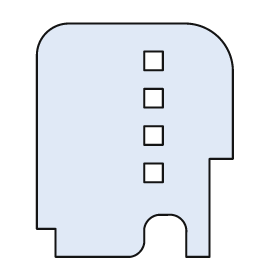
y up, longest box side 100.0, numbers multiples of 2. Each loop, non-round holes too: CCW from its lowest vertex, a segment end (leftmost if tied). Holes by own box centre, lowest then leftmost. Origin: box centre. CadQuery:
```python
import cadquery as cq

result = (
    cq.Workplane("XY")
    .moveTo(-34.0, -50.0)
    .lineTo(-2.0, -50.0)
    .threePointArc((2.0, -48.0), (4.0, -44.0))
    .lineTo(4.0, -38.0)
    .threePointArc((6.0, -34.0), (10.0, -32.0))
    .lineTo(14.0, -32.0)
    .threePointArc((20.0, -34.0), (22.0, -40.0))
    .lineTo(22.0, -50.0)
    .lineTo(32.0, -50.0)
    .lineTo(32.0, -8.0)
    .lineTo(42.0, -8.0)
    .lineTo(42.0, 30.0)
    .threePointArc((36.0, 44.0), (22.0, 50.0))
    .lineTo(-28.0, 50.0)
    .threePointArc((-38.0, 46.0), (-42.0, 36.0))
    .lineTo(-42.0, -38.0)
    .lineTo(-34.0, -38.0)
    .close()
    .moveTo(4.0, -18.0)
    .lineTo(12.0, -18.0)
    .lineTo(12.0, -10.0)
    .lineTo(4.0, -10.0)
    .close()
    .moveTo(4.0, -2.0)
    .lineTo(12.0, -2.0)
    .lineTo(12.0, 6.0)
    .lineTo(4.0, 6.0)
    .close()
    .moveTo(4.0, 14.0)
    .lineTo(12.0, 14.0)
    .lineTo(12.0, 22.0)
    .lineTo(4.0, 22.0)
    .close()
    .moveTo(4.0, 30.0)
    .lineTo(12.0, 30.0)
    .lineTo(12.0, 38.0)
    .lineTo(4.0, 38.0)
    .close()
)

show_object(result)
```